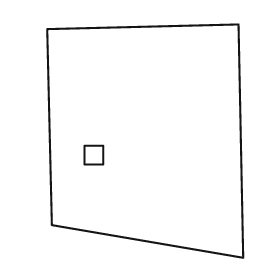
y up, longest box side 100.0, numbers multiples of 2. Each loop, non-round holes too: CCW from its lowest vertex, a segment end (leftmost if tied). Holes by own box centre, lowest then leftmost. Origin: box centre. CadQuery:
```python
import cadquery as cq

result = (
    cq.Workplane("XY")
    .moveTo(42.0, -50.0)
    .lineTo(40.0, 50.0)
    .lineTo(-42.0, 48.0)
    .lineTo(-40.0, -36.0)
    .close()
    .moveTo(-26.0, -10.0)
    .lineTo(-18.0, -10.0)
    .lineTo(-18.0, -2.0)
    .lineTo(-26.0, -2.0)
    .close()
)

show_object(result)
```